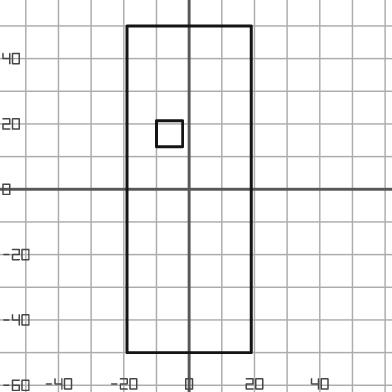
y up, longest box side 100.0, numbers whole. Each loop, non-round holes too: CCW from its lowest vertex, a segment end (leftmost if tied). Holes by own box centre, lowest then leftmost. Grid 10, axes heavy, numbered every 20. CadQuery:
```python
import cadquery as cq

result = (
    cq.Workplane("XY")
    .moveTo(-19.0, -50.0)
    .lineTo(19.0, -50.0)
    .lineTo(19.0, 50.0)
    .lineTo(-19.0, 50.0)
    .close()
    .moveTo(-10.0, 13.0)
    .lineTo(-2.0, 13.0)
    .lineTo(-2.0, 21.0)
    .lineTo(-10.0, 21.0)
    .close()
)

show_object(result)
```